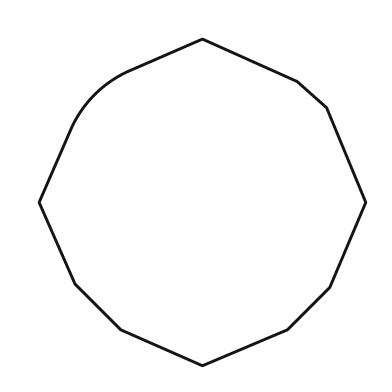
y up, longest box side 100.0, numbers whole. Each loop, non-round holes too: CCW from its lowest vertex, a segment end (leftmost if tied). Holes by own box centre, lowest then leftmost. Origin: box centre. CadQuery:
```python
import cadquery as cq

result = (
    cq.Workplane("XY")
    .moveTo(0.0, -50.0)
    .lineTo(26.0, -39.0)
    .lineTo(39.0, -26.0)
    .lineTo(50.0, 0.0)
    .lineTo(38.0, 29.0)
    .lineTo(29.0, 37.0)
    .lineTo(0.0, 50.0)
    .lineTo(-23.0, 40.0)
    .threePointArc((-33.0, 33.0), (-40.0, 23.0))
    .lineTo(-50.0, 0.0)
    .lineTo(-39.0, -25.0)
    .lineTo(-25.0, -39.0)
    .close()
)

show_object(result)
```